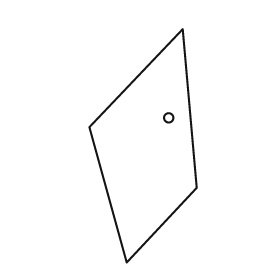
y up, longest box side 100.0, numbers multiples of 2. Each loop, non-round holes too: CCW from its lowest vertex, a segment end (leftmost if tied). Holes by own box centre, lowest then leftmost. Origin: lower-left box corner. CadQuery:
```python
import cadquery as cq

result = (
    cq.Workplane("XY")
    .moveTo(16.0, 0.0)
    .lineTo(46.0, 32.0)
    .lineTo(40.0, 100.0)
    .lineTo(0.0, 58.0)
    .close()
    .moveTo(34.0, 62.0)
    .circle(2.0)
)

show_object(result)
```